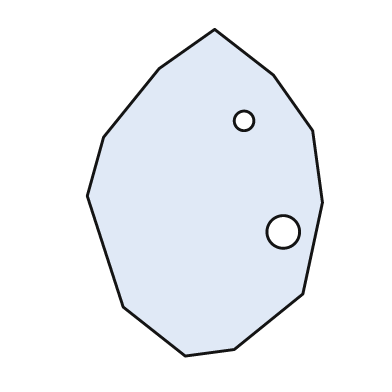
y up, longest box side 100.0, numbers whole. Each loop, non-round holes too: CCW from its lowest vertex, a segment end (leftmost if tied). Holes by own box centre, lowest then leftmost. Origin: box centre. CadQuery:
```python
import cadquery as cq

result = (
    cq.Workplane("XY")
    .moveTo(-6.0, -50.0)
    .lineTo(9.0, -48.0)
    .lineTo(30.0, -31.0)
    .lineTo(36.0, -3.0)
    .lineTo(33.0, 19.0)
    .lineTo(21.0, 36.0)
    .lineTo(3.0, 50.0)
    .lineTo(-14.0, 38.0)
    .lineTo(-31.0, 17.0)
    .lineTo(-36.0, -1.0)
    .lineTo(-25.0, -35.0)
    .close()
    .moveTo(24.0, -12.0)
    .circle(5.0)
    .moveTo(12.0, 22.0)
    .circle(3.0)
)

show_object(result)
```